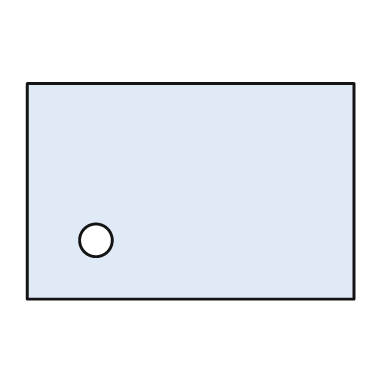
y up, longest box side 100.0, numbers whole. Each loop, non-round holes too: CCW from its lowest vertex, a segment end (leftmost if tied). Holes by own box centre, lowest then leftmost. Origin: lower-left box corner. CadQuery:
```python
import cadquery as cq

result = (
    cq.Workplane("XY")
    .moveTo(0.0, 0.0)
    .lineTo(100.0, 0.0)
    .lineTo(100.0, 66.0)
    .lineTo(0.0, 66.0)
    .close()
    .moveTo(21.0, 18.0)
    .circle(5.0)
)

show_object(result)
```